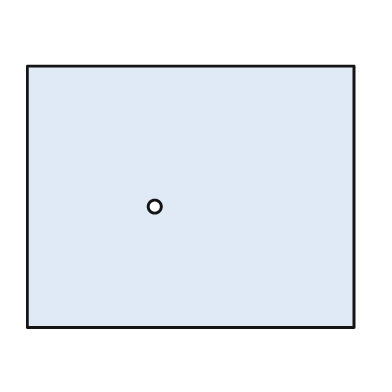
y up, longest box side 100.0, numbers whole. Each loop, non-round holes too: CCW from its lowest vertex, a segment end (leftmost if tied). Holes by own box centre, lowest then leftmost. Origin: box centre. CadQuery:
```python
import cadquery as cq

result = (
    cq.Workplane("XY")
    .moveTo(-50.0, -40.0)
    .lineTo(50.0, -40.0)
    .lineTo(50.0, 40.0)
    .lineTo(-50.0, 40.0)
    .close()
    .moveTo(-11.0, -3.0)
    .circle(2.0)
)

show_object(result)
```